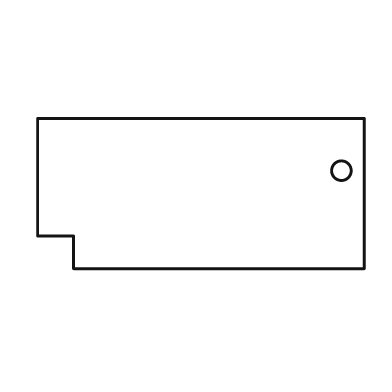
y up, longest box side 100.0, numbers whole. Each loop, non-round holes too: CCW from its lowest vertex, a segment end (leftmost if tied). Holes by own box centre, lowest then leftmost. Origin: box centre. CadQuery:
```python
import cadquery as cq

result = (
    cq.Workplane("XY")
    .moveTo(-39.0, -23.0)
    .lineTo(50.0, -23.0)
    .lineTo(50.0, 23.0)
    .lineTo(-50.0, 23.0)
    .lineTo(-50.0, -13.0)
    .lineTo(-39.0, -13.0)
    .close()
    .moveTo(43.0, 7.0)
    .circle(3.0)
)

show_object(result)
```